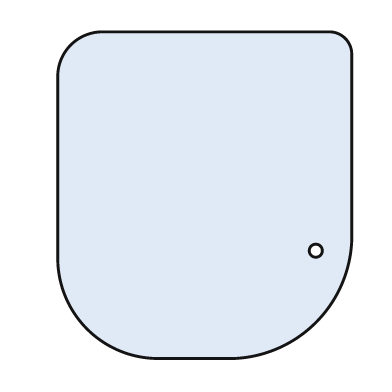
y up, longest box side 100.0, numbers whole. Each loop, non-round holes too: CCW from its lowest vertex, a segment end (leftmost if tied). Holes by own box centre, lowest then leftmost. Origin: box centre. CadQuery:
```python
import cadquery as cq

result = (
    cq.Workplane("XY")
    .moveTo(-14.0, -50.0)
    .lineTo(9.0, -50.0)
    .threePointArc((34.0, -39.0), (45.0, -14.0))
    .lineTo(45.0, 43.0)
    .threePointArc((43.0, 48.0), (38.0, 50.0))
    .lineTo(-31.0, 50.0)
    .threePointArc((-41.0, 46.0), (-45.0, 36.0))
    .lineTo(-45.0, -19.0)
    .threePointArc((-36.0, -41.0), (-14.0, -50.0))
    .close()
    .moveTo(34.0, -17.0)
    .circle(2.0)
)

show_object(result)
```